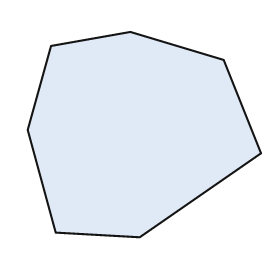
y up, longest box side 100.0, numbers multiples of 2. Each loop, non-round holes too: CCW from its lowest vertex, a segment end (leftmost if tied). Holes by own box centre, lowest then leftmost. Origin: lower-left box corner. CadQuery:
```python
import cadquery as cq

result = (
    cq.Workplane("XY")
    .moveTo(48.0, 0.0)
    .lineTo(100.0, 36.0)
    .lineTo(84.0, 76.0)
    .lineTo(44.0, 88.0)
    .lineTo(10.0, 82.0)
    .lineTo(0.0, 46.0)
    .lineTo(12.0, 2.0)
    .close()
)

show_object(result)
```